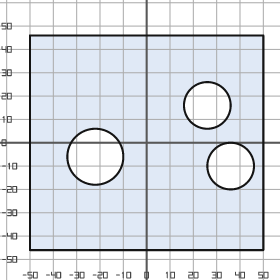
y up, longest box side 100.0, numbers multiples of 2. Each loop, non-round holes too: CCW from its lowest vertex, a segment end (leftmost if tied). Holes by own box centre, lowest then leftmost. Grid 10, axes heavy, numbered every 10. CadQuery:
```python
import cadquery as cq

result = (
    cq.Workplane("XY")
    .moveTo(-50.0, -46.0)
    .lineTo(50.0, -46.0)
    .lineTo(50.0, 46.0)
    .lineTo(-50.0, 46.0)
    .close()
    .moveTo(36.0, -10.0)
    .circle(10.0)
    .moveTo(-22.0, -6.0)
    .circle(12.0)
    .moveTo(26.0, 16.0)
    .circle(10.0)
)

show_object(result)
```